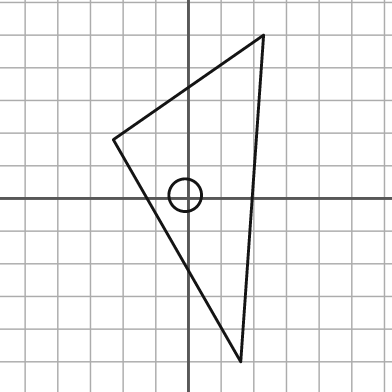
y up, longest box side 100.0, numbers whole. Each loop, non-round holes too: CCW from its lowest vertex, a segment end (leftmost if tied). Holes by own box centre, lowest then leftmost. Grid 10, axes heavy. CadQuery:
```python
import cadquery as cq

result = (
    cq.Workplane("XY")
    .moveTo(16.0, -50.0)
    .lineTo(23.0, 50.0)
    .lineTo(-23.0, 18.0)
    .close()
    .moveTo(-1.0, 1.0)
    .circle(5.0)
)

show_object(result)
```